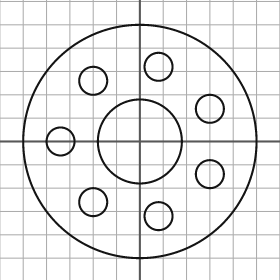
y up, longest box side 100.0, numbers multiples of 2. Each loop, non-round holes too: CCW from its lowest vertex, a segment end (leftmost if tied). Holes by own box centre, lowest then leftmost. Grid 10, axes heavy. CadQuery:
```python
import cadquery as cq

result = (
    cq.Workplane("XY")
    .moveTo(0.0, 0.0)
    .circle(50.0)
    .moveTo(8.0, -32.0)
    .circle(6.0)
    .moveTo(-20.0, -26.0)
    .circle(6.0)
    .moveTo(30.0, -14.0)
    .circle(6.0)
    .moveTo(-34.0, 0.0)
    .circle(6.0)
    .moveTo(0.0, 0.0)
    .circle(18.0)
    .moveTo(30.0, 14.0)
    .circle(6.0)
    .moveTo(-20.0, 26.0)
    .circle(6.0)
    .moveTo(8.0, 32.0)
    .circle(6.0)
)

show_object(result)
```